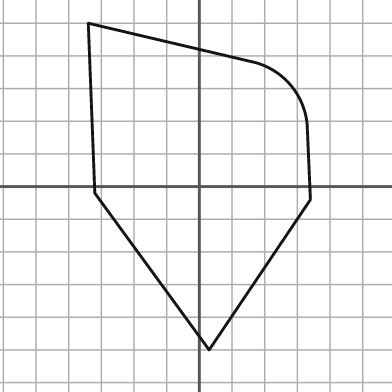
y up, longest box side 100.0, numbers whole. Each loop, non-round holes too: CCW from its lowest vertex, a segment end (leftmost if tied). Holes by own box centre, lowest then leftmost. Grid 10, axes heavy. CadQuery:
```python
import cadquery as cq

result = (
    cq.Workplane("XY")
    .moveTo(3.0, -50.0)
    .lineTo(34.0, -4.0)
    .lineTo(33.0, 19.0)
    .threePointArc((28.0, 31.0), (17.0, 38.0))
    .lineTo(-34.0, 50.0)
    .lineTo(-32.0, -2.0)
    .close()
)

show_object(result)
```